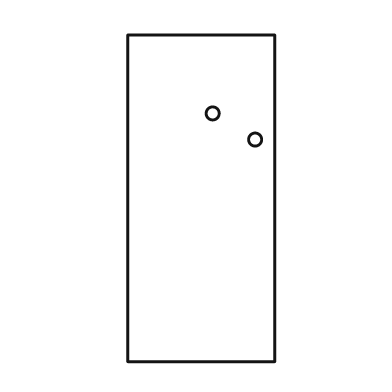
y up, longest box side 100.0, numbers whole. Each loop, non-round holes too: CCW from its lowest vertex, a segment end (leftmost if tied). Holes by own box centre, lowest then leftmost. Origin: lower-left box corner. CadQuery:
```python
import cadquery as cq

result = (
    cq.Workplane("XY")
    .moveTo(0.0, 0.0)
    .lineTo(45.0, 0.0)
    .lineTo(45.0, 100.0)
    .lineTo(0.0, 100.0)
    .close()
    .moveTo(39.0, 68.0)
    .circle(2.0)
    .moveTo(26.0, 76.0)
    .circle(2.0)
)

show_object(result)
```